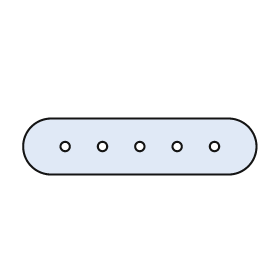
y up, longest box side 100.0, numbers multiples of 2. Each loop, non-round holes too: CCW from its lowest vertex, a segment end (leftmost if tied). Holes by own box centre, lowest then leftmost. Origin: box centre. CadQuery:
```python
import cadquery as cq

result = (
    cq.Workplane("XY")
    .moveTo(-38.0, -12.0)
    .lineTo(38.0, -12.0)
    .threePointArc((50.0, 0.0), (38.0, 12.0))
    .lineTo(-38.0, 12.0)
    .threePointArc((-50.0, 0.0), (-38.0, -12.0))
    .close()
    .moveTo(-32.0, 0.0)
    .circle(2.0)
    .moveTo(-16.0, 0.0)
    .circle(2.0)
    .moveTo(0.0, 0.0)
    .circle(2.0)
    .moveTo(16.0, 0.0)
    .circle(2.0)
    .moveTo(32.0, 0.0)
    .circle(2.0)
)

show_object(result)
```